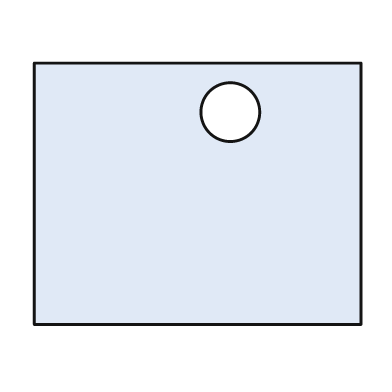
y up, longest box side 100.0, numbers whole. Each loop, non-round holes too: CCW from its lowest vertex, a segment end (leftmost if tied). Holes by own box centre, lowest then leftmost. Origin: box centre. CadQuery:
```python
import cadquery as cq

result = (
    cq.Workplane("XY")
    .moveTo(-50.0, -40.0)
    .lineTo(50.0, -40.0)
    .lineTo(50.0, 40.0)
    .lineTo(-50.0, 40.0)
    .close()
    .moveTo(10.0, 25.0)
    .circle(9.0)
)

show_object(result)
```